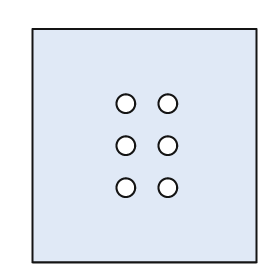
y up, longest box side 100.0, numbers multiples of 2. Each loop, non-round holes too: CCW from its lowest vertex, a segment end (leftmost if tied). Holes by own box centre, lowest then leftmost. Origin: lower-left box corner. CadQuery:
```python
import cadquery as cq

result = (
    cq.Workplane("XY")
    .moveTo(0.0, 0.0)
    .lineTo(96.0, 0.0)
    .lineTo(96.0, 100.0)
    .lineTo(0.0, 100.0)
    .close()
    .moveTo(40.0, 32.0)
    .circle(4.0)
    .moveTo(58.0, 32.0)
    .circle(4.0)
    .moveTo(40.0, 50.0)
    .circle(4.0)
    .moveTo(58.0, 50.0)
    .circle(4.0)
    .moveTo(40.0, 68.0)
    .circle(4.0)
    .moveTo(58.0, 68.0)
    .circle(4.0)
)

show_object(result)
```